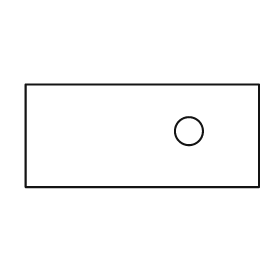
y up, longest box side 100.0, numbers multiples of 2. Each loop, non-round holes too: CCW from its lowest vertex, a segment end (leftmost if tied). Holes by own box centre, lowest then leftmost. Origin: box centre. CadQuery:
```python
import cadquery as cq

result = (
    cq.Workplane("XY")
    .moveTo(-50.0, -22.0)
    .lineTo(50.0, -22.0)
    .lineTo(50.0, 22.0)
    .lineTo(-50.0, 22.0)
    .close()
    .moveTo(20.0, 2.0)
    .circle(6.0)
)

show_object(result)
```